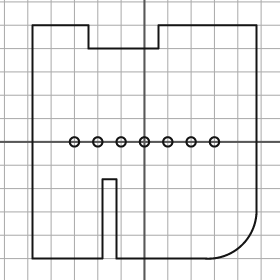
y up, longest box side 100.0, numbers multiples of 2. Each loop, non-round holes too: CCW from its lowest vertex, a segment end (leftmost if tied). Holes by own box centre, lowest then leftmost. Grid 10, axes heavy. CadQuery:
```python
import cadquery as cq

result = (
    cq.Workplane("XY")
    .moveTo(-48.0, -50.0)
    .lineTo(-18.0, -50.0)
    .lineTo(-18.0, -16.0)
    .lineTo(-12.0, -16.0)
    .lineTo(-12.0, -50.0)
    .lineTo(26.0, -50.0)
    .threePointArc((42.0, -44.0), (48.0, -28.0))
    .lineTo(48.0, 50.0)
    .lineTo(6.0, 50.0)
    .lineTo(6.0, 40.0)
    .lineTo(-24.0, 40.0)
    .lineTo(-24.0, 50.0)
    .lineTo(-48.0, 50.0)
    .close()
    .moveTo(-30.0, 0.0)
    .circle(2.0)
    .moveTo(-20.0, 0.0)
    .circle(2.0)
    .moveTo(-10.0, 0.0)
    .circle(2.0)
    .moveTo(0.0, 0.0)
    .circle(2.0)
    .moveTo(10.0, 0.0)
    .circle(2.0)
    .moveTo(20.0, 0.0)
    .circle(2.0)
    .moveTo(30.0, 0.0)
    .circle(2.0)
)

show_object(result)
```